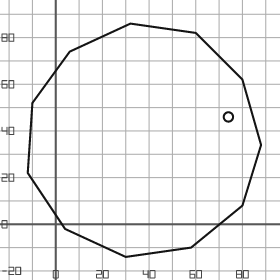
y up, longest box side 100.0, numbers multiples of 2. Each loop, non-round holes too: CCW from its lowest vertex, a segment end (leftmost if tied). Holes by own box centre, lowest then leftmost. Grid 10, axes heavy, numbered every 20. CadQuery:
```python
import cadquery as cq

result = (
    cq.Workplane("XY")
    .moveTo(30.0, -14.0)
    .lineTo(58.0, -10.0)
    .lineTo(80.0, 8.0)
    .lineTo(88.0, 34.0)
    .lineTo(80.0, 62.0)
    .lineTo(60.0, 82.0)
    .lineTo(32.0, 86.0)
    .lineTo(6.0, 74.0)
    .lineTo(-10.0, 52.0)
    .lineTo(-12.0, 22.0)
    .lineTo(4.0, -2.0)
    .close()
    .moveTo(74.0, 46.0)
    .circle(2.0)
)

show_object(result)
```